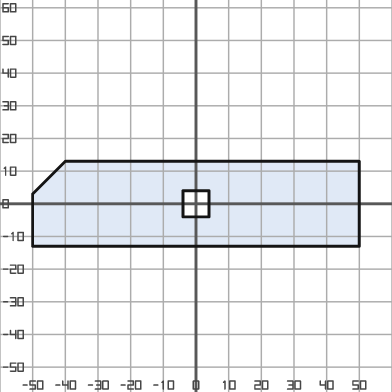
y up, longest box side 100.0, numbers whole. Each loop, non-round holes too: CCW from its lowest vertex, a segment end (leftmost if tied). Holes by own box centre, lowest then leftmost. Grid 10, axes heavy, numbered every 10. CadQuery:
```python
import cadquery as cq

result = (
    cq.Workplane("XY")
    .moveTo(-50.0, -13.0)
    .lineTo(50.0, -13.0)
    .lineTo(50.0, 13.0)
    .lineTo(-40.0, 13.0)
    .lineTo(-50.0, 3.0)
    .close()
    .moveTo(-4.0, -4.0)
    .lineTo(4.0, -4.0)
    .lineTo(4.0, 4.0)
    .lineTo(-4.0, 4.0)
    .close()
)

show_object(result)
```